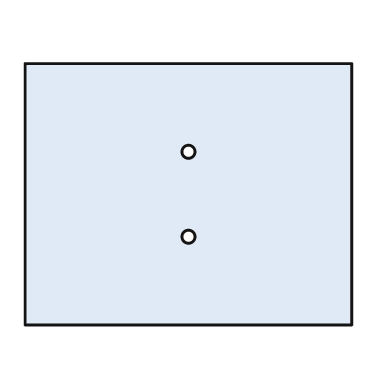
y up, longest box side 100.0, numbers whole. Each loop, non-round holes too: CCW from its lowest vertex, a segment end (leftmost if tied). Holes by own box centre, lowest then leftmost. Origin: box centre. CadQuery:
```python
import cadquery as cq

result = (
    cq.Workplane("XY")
    .moveTo(-50.0, -40.0)
    .lineTo(50.0, -40.0)
    .lineTo(50.0, 40.0)
    .lineTo(-50.0, 40.0)
    .close()
    .moveTo(0.0, -13.0)
    .circle(2.0)
    .moveTo(0.0, 13.0)
    .circle(2.0)
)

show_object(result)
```